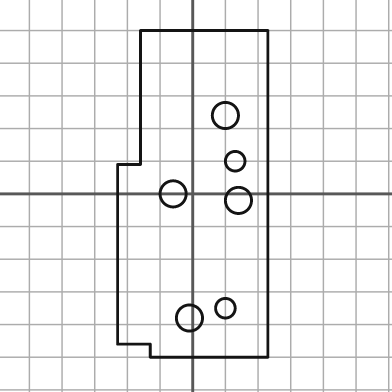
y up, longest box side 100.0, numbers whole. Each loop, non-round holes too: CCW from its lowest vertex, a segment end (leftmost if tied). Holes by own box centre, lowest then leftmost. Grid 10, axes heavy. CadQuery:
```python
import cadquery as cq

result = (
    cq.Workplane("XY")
    .moveTo(-13.0, -50.0)
    .lineTo(23.0, -50.0)
    .lineTo(23.0, 50.0)
    .lineTo(-16.0, 50.0)
    .lineTo(-16.0, 9.0)
    .lineTo(-23.0, 9.0)
    .lineTo(-23.0, -46.0)
    .lineTo(-13.0, -46.0)
    .close()
    .moveTo(-1.0, -38.0)
    .circle(4.0)
    .moveTo(10.0, -35.0)
    .circle(3.0)
    .moveTo(14.0, -2.0)
    .circle(4.0)
    .moveTo(-6.0, 0.0)
    .circle(4.0)
    .moveTo(13.0, 10.0)
    .circle(3.0)
    .moveTo(10.0, 24.0)
    .circle(4.0)
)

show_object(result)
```